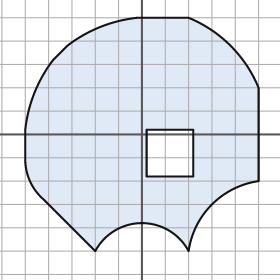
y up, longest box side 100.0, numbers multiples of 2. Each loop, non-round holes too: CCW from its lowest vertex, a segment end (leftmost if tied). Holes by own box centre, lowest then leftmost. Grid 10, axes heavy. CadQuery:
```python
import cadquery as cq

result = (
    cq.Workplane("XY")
    .moveTo(-20.0, -50.0)
    .threePointArc((0.0, -38.0), (20.0, -50.0))
    .threePointArc((30.0, -30.0), (50.0, -20.0))
    .lineTo(50.0, 20.0)
    .threePointArc((38.0, 38.0), (20.0, 50.0))
    .lineTo(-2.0, 50.0)
    .threePointArc((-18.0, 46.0), (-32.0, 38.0))
    .lineTo(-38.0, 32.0)
    .threePointArc((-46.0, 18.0), (-50.0, 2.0))
    .lineTo(-50.0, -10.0)
    .threePointArc((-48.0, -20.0), (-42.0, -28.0))
    .close()
    .moveTo(2.0, -18.0)
    .lineTo(22.0, -18.0)
    .lineTo(22.0, 2.0)
    .lineTo(2.0, 2.0)
    .close()
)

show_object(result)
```